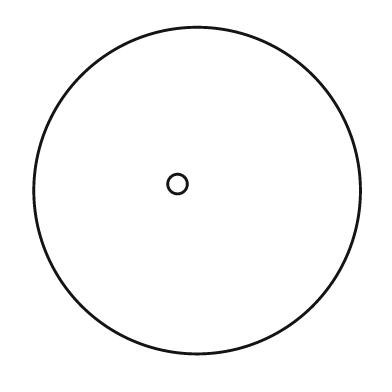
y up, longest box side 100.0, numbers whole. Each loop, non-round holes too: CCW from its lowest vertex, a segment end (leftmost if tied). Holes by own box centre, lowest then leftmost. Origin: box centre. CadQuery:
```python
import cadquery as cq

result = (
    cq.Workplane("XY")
    .moveTo(0.0, 0.0)
    .circle(50.0)
    .moveTo(-6.0, 2.0)
    .circle(3.0)
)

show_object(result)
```